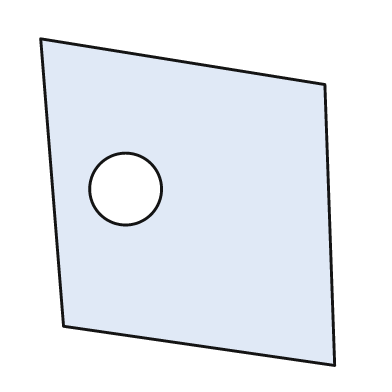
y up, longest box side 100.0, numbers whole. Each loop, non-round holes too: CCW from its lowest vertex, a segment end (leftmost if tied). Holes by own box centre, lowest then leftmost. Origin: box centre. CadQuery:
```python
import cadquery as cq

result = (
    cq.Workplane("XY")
    .moveTo(45.0, -50.0)
    .lineTo(42.0, 36.0)
    .lineTo(-45.0, 50.0)
    .lineTo(-38.0, -38.0)
    .close()
    .moveTo(-19.0, 4.0)
    .circle(11.0)
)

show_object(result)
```